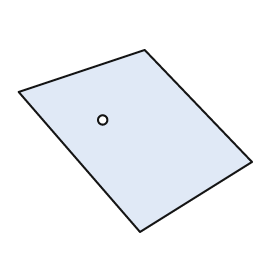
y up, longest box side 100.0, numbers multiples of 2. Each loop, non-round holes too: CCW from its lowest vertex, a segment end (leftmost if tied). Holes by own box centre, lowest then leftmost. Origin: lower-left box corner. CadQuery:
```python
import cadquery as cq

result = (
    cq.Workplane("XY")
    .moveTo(52.0, 0.0)
    .lineTo(100.0, 30.0)
    .lineTo(54.0, 78.0)
    .lineTo(0.0, 60.0)
    .close()
    .moveTo(36.0, 48.0)
    .circle(2.0)
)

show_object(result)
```